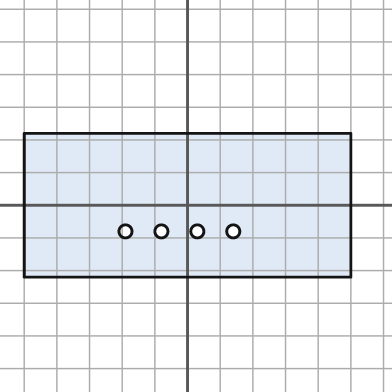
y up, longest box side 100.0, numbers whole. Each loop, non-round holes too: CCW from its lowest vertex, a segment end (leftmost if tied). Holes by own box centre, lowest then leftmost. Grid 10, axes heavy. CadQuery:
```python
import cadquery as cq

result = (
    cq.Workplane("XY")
    .moveTo(-50.0, -22.0)
    .lineTo(50.0, -22.0)
    .lineTo(50.0, 22.0)
    .lineTo(-50.0, 22.0)
    .close()
    .moveTo(-19.0, -8.0)
    .circle(2.0)
    .moveTo(-8.0, -8.0)
    .circle(2.0)
    .moveTo(3.0, -8.0)
    .circle(2.0)
    .moveTo(14.0, -8.0)
    .circle(2.0)
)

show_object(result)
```